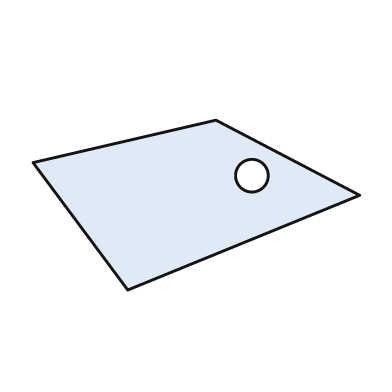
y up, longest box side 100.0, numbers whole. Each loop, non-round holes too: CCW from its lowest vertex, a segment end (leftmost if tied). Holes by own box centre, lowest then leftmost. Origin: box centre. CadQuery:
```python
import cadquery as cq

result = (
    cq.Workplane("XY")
    .moveTo(-21.0, -26.0)
    .lineTo(50.0, 3.0)
    .lineTo(6.0, 26.0)
    .lineTo(-50.0, 13.0)
    .close()
    .moveTo(17.0, 9.0)
    .circle(5.0)
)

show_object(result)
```